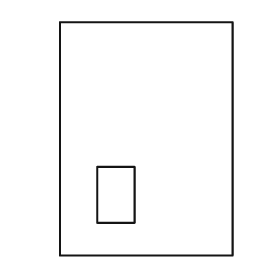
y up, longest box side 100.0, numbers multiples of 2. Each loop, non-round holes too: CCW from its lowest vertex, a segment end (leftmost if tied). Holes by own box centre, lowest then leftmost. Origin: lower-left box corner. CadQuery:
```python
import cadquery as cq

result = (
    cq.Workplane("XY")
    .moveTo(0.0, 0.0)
    .lineTo(74.0, 0.0)
    .lineTo(74.0, 100.0)
    .lineTo(0.0, 100.0)
    .close()
    .moveTo(16.0, 14.0)
    .lineTo(32.0, 14.0)
    .lineTo(32.0, 38.0)
    .lineTo(16.0, 38.0)
    .close()
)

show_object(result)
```